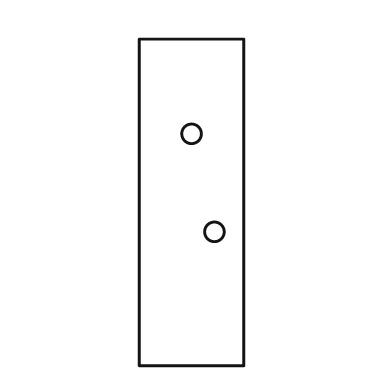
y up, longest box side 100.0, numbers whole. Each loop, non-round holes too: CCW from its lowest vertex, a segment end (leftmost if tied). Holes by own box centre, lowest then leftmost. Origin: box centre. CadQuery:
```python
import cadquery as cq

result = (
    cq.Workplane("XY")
    .moveTo(-16.0, -50.0)
    .lineTo(16.0, -50.0)
    .lineTo(16.0, 50.0)
    .lineTo(-16.0, 50.0)
    .close()
    .moveTo(7.0, -9.0)
    .circle(3.0)
    .moveTo(0.0, 21.0)
    .circle(3.0)
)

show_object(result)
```